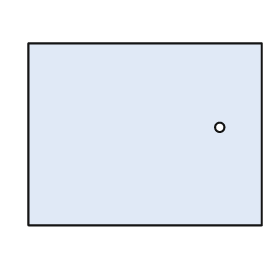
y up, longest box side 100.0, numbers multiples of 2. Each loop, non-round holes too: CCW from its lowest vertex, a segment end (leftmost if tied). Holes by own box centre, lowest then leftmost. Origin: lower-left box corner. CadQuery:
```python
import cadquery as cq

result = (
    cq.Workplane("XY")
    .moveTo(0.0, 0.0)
    .lineTo(100.0, 0.0)
    .lineTo(100.0, 78.0)
    .lineTo(0.0, 78.0)
    .close()
    .moveTo(82.0, 42.0)
    .circle(2.0)
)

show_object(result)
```